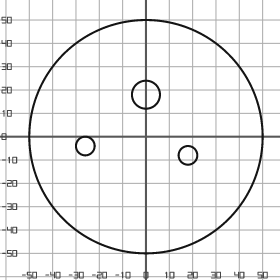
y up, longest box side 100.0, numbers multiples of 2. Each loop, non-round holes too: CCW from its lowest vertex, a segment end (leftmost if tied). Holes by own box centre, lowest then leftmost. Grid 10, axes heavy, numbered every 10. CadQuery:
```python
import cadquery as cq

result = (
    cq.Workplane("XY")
    .moveTo(0.0, 0.0)
    .circle(50.0)
    .moveTo(18.0, -8.0)
    .circle(4.0)
    .moveTo(-26.0, -4.0)
    .circle(4.0)
    .moveTo(0.0, 18.0)
    .circle(6.0)
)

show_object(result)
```